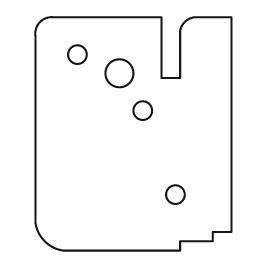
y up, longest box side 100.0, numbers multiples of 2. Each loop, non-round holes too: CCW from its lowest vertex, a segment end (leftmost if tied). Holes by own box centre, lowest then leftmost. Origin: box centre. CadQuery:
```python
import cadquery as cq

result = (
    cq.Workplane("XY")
    .moveTo(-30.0, -50.0)
    .lineTo(20.0, -50.0)
    .lineTo(20.0, -46.0)
    .lineTo(34.0, -46.0)
    .lineTo(34.0, -42.0)
    .lineTo(42.0, -42.0)
    .lineTo(42.0, 50.0)
    .lineTo(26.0, 50.0)
    .threePointArc((22.0, 48.0), (20.0, 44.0))
    .lineTo(20.0, 24.0)
    .lineTo(12.0, 24.0)
    .lineTo(12.0, 50.0)
    .lineTo(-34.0, 50.0)
    .threePointArc((-40.0, 48.0), (-42.0, 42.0))
    .lineTo(-42.0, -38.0)
    .threePointArc((-38.0, -46.0), (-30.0, -50.0))
    .close()
    .moveTo(18.0, -26.0)
    .circle(4.0)
    .moveTo(4.0, 10.0)
    .circle(4.0)
    .moveTo(-6.0, 26.0)
    .circle(6.0)
    .moveTo(-24.0, 34.0)
    .circle(4.0)
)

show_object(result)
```